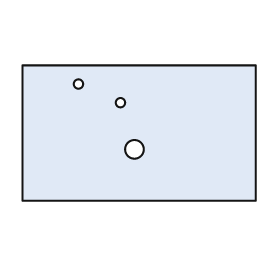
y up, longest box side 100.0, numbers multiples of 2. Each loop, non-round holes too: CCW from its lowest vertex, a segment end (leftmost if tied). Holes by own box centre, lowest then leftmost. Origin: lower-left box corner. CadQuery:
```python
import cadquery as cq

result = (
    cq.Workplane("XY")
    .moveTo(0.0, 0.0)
    .lineTo(100.0, 0.0)
    .lineTo(100.0, 58.0)
    .lineTo(0.0, 58.0)
    .close()
    .moveTo(48.0, 22.0)
    .circle(4.0)
    .moveTo(42.0, 42.0)
    .circle(2.0)
    .moveTo(24.0, 50.0)
    .circle(2.0)
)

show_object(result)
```